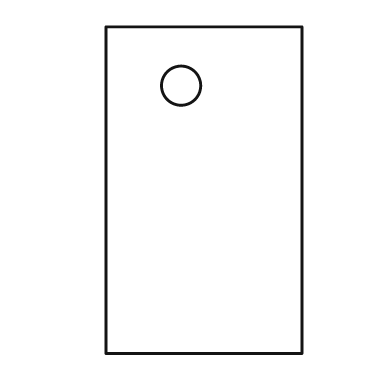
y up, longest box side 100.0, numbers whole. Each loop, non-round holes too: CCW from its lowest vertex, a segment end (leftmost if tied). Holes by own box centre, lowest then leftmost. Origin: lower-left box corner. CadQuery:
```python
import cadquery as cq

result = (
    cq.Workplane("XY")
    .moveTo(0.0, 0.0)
    .lineTo(60.0, 0.0)
    .lineTo(60.0, 100.0)
    .lineTo(0.0, 100.0)
    .close()
    .moveTo(23.0, 82.0)
    .circle(6.0)
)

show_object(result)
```